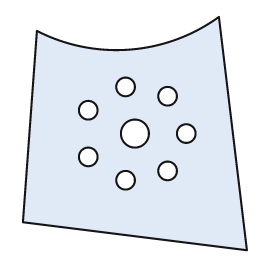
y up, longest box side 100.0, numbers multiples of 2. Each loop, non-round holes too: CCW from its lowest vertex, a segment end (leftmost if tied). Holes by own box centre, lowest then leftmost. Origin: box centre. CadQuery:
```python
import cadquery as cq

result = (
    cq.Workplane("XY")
    .moveTo(48.0, -50.0)
    .lineTo(36.0, 50.0)
    .threePointArc((-2.0, 36.0), (-42.0, 44.0))
    .lineTo(-48.0, -38.0)
    .close()
    .moveTo(-4.0, -20.0)
    .circle(4.0)
    .moveTo(14.0, -16.0)
    .circle(4.0)
    .moveTo(-20.0, -10.0)
    .circle(4.0)
    .moveTo(0.0, 0.0)
    .circle(6.0)
    .moveTo(22.0, 0.0)
    .circle(4.0)
    .moveTo(-20.0, 10.0)
    .circle(4.0)
    .moveTo(14.0, 16.0)
    .circle(4.0)
    .moveTo(-4.0, 20.0)
    .circle(4.0)
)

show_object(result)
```